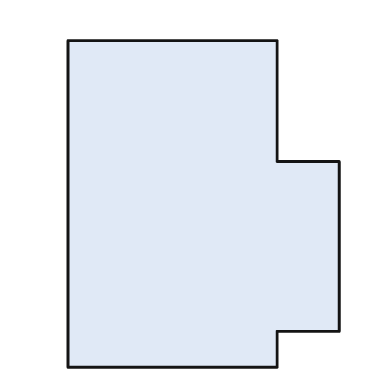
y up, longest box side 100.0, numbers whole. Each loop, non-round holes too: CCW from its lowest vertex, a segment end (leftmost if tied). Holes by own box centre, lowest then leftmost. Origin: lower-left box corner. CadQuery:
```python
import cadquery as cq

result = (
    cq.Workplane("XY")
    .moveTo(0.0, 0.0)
    .lineTo(64.0, 0.0)
    .lineTo(64.0, 11.0)
    .lineTo(83.0, 11.0)
    .lineTo(83.0, 63.0)
    .lineTo(64.0, 63.0)
    .lineTo(64.0, 100.0)
    .lineTo(0.0, 100.0)
    .close()
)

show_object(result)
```